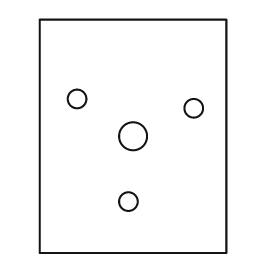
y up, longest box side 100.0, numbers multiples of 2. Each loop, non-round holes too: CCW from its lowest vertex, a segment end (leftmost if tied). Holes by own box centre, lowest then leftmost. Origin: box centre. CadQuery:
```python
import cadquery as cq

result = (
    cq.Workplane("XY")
    .moveTo(-40.0, -50.0)
    .lineTo(40.0, -50.0)
    .lineTo(40.0, 50.0)
    .lineTo(-40.0, 50.0)
    .close()
    .moveTo(-2.0, -28.0)
    .circle(4.0)
    .moveTo(0.0, 0.0)
    .circle(6.0)
    .moveTo(26.0, 12.0)
    .circle(4.0)
    .moveTo(-24.0, 16.0)
    .circle(4.0)
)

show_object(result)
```